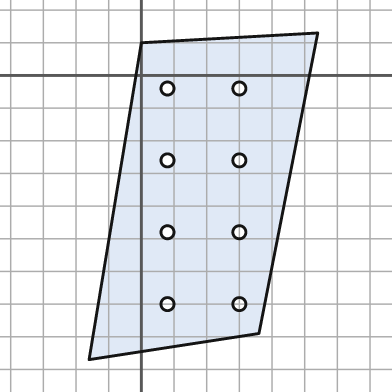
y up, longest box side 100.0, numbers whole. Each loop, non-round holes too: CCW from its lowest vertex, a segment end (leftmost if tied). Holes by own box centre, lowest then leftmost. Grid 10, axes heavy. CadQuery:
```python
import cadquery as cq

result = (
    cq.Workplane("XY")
    .moveTo(-16.0, -87.0)
    .lineTo(36.0, -79.0)
    .lineTo(54.0, 13.0)
    .lineTo(0.0, 10.0)
    .close()
    .moveTo(8.0, -70.0)
    .circle(2.0)
    .moveTo(30.0, -70.0)
    .circle(2.0)
    .moveTo(8.0, -48.0)
    .circle(2.0)
    .moveTo(30.0, -48.0)
    .circle(2.0)
    .moveTo(8.0, -26.0)
    .circle(2.0)
    .moveTo(30.0, -26.0)
    .circle(2.0)
    .moveTo(8.0, -4.0)
    .circle(2.0)
    .moveTo(30.0, -4.0)
    .circle(2.0)
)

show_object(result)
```